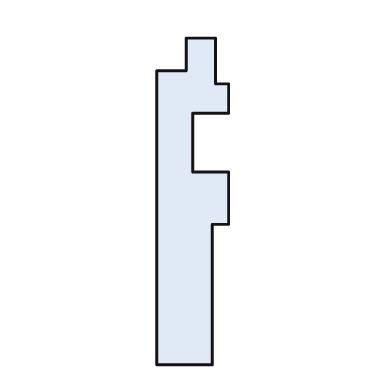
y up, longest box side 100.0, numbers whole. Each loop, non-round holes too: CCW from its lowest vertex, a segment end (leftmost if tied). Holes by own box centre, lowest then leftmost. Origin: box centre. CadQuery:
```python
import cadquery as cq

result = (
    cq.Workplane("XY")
    .moveTo(-11.0, -50.0)
    .lineTo(6.0, -50.0)
    .lineTo(6.0, -7.0)
    .lineTo(11.0, -7.0)
    .lineTo(11.0, 9.0)
    .lineTo(0.0, 9.0)
    .lineTo(0.0, 27.0)
    .lineTo(11.0, 27.0)
    .lineTo(11.0, 36.0)
    .lineTo(7.0, 36.0)
    .lineTo(7.0, 50.0)
    .lineTo(-2.0, 50.0)
    .lineTo(-2.0, 40.0)
    .lineTo(-11.0, 40.0)
    .close()
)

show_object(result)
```